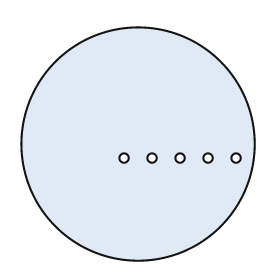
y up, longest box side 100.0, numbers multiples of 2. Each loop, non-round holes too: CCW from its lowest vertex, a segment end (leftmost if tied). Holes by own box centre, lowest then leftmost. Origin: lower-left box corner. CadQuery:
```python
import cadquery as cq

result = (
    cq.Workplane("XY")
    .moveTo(50.0, 50.0)
    .circle(50.0)
    .moveTo(44.0, 44.0)
    .circle(2.0)
    .moveTo(56.0, 44.0)
    .circle(2.0)
    .moveTo(68.0, 44.0)
    .circle(2.0)
    .moveTo(80.0, 44.0)
    .circle(2.0)
    .moveTo(92.0, 44.0)
    .circle(2.0)
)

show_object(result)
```